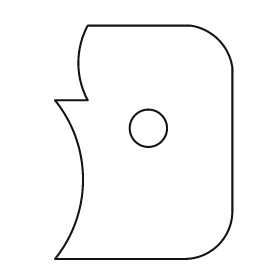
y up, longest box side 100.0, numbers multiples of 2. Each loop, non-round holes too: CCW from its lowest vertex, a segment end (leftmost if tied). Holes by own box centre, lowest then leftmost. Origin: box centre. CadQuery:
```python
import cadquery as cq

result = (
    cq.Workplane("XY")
    .moveTo(-38.0, -50.0)
    .lineTo(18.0, -50.0)
    .threePointArc((32.0, -44.0), (38.0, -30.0))
    .lineTo(38.0, 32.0)
    .threePointArc((32.0, 44.0), (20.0, 50.0))
    .lineTo(-24.0, 50.0)
    .threePointArc((-28.0, 34.0), (-24.0, 18.0))
    .lineTo(-38.0, 18.0)
    .threePointArc((-26.0, -16.0), (-38.0, -50.0))
    .close()
    .moveTo(2.0, 6.0)
    .circle(8.0)
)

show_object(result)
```